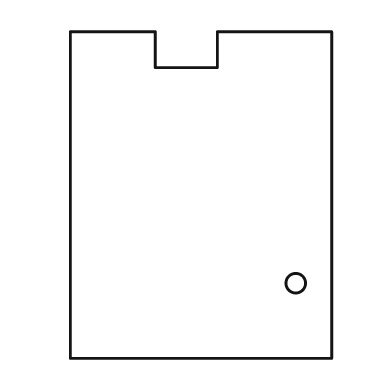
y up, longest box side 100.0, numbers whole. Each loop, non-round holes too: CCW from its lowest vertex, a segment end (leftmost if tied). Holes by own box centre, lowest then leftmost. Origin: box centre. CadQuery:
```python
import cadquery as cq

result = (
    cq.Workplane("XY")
    .moveTo(-40.0, -50.0)
    .lineTo(40.0, -50.0)
    .lineTo(40.0, 50.0)
    .lineTo(5.0, 50.0)
    .lineTo(5.0, 39.0)
    .lineTo(-14.0, 39.0)
    .lineTo(-14.0, 50.0)
    .lineTo(-40.0, 50.0)
    .close()
    .moveTo(29.0, -27.0)
    .circle(3.0)
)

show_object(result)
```